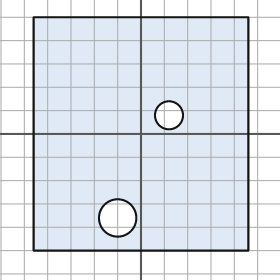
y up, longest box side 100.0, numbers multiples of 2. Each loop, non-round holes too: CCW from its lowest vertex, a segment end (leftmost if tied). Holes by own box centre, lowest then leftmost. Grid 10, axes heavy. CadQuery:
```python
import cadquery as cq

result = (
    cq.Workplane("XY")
    .moveTo(-46.0, -50.0)
    .lineTo(46.0, -50.0)
    .lineTo(46.0, 50.0)
    .lineTo(-46.0, 50.0)
    .close()
    .moveTo(-10.0, -36.0)
    .circle(8.0)
    .moveTo(12.0, 8.0)
    .circle(6.0)
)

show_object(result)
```